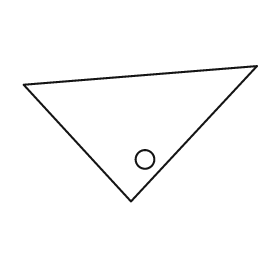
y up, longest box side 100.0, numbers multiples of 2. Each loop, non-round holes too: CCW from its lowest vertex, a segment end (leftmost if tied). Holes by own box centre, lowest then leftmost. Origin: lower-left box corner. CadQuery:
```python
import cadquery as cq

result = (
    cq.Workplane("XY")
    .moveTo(46.0, 0.0)
    .lineTo(100.0, 58.0)
    .lineTo(0.0, 50.0)
    .close()
    .moveTo(52.0, 18.0)
    .circle(4.0)
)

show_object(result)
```